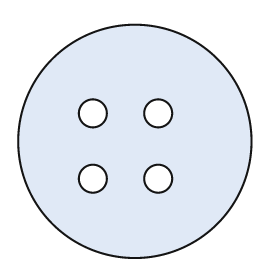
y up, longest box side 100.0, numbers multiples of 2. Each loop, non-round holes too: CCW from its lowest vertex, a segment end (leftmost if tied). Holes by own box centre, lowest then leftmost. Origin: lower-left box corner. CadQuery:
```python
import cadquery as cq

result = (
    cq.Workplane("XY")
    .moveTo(50.0, 50.0)
    .circle(50.0)
    .moveTo(32.0, 34.0)
    .circle(6.0)
    .moveTo(60.0, 34.0)
    .circle(6.0)
    .moveTo(32.0, 62.0)
    .circle(6.0)
    .moveTo(60.0, 62.0)
    .circle(6.0)
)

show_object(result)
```